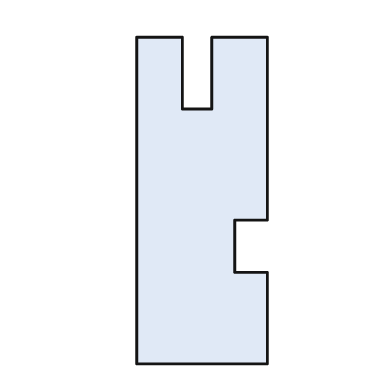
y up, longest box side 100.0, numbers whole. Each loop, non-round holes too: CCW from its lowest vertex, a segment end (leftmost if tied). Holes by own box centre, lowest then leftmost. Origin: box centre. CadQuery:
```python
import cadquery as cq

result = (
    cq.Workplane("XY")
    .moveTo(-20.0, -50.0)
    .lineTo(20.0, -50.0)
    .lineTo(20.0, -22.0)
    .lineTo(10.0, -22.0)
    .lineTo(10.0, -6.0)
    .lineTo(20.0, -6.0)
    .lineTo(20.0, 50.0)
    .lineTo(3.0, 50.0)
    .lineTo(3.0, 28.0)
    .lineTo(-6.0, 28.0)
    .lineTo(-6.0, 50.0)
    .lineTo(-20.0, 50.0)
    .close()
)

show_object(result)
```